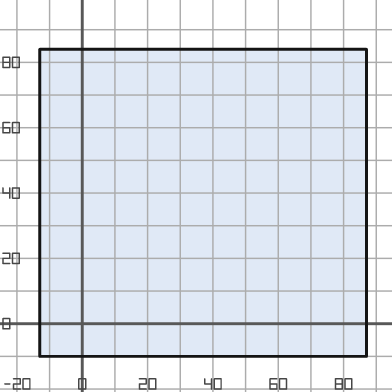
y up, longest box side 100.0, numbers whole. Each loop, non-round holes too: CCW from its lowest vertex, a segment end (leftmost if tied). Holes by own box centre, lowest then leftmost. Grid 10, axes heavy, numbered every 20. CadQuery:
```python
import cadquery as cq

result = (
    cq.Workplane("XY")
    .moveTo(-13.0, -10.0)
    .lineTo(87.0, -10.0)
    .lineTo(87.0, 84.0)
    .lineTo(-13.0, 84.0)
    .close()
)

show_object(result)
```